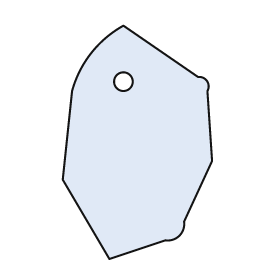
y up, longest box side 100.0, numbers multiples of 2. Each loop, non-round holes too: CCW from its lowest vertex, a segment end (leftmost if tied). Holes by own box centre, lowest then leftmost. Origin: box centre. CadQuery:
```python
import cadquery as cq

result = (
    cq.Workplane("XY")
    .moveTo(-12.0, -50.0)
    .lineTo(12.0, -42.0)
    .threePointArc((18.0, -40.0), (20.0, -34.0))
    .lineTo(32.0, -8.0)
    .lineTo(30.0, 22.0)
    .threePointArc((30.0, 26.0), (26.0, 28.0))
    .lineTo(-6.0, 50.0)
    .threePointArc((-20.0, 38.0), (-28.0, 22.0))
    .lineTo(-32.0, -16.0)
    .close()
    .moveTo(-6.0, 26.0)
    .circle(4.0)
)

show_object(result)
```